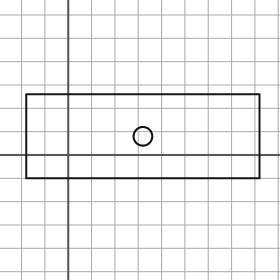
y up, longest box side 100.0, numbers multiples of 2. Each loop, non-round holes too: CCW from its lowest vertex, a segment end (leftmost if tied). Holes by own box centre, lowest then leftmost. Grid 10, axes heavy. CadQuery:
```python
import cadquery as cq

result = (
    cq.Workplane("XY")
    .moveTo(-18.0, -10.0)
    .lineTo(82.0, -10.0)
    .lineTo(82.0, 26.0)
    .lineTo(-18.0, 26.0)
    .close()
    .moveTo(32.0, 8.0)
    .circle(4.0)
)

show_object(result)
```